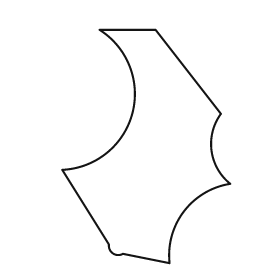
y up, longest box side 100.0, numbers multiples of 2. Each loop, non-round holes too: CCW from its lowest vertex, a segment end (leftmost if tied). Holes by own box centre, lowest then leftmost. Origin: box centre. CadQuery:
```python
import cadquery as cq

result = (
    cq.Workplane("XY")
    .moveTo(10.0, -50.0)
    .threePointArc((16.0, -28.0), (36.0, -16.0))
    .threePointArc((28.0, -2.0), (32.0, 14.0))
    .lineTo(4.0, 50.0)
    .lineTo(-20.0, 50.0)
    .threePointArc((-6.0, 14.0), (-36.0, -10.0))
    .lineTo(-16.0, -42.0)
    .threePointArc((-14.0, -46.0), (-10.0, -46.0))
    .close()
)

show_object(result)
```